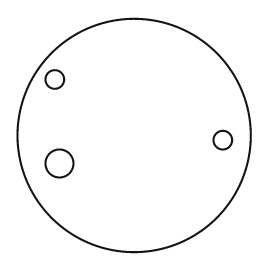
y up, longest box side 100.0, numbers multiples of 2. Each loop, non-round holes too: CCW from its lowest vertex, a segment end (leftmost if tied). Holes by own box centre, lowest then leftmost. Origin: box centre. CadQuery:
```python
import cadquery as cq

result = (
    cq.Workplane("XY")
    .moveTo(0.0, 0.0)
    .circle(50.0)
    .moveTo(-32.0, -12.0)
    .circle(6.0)
    .moveTo(38.0, -2.0)
    .circle(4.0)
    .moveTo(-34.0, 24.0)
    .circle(4.0)
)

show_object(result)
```